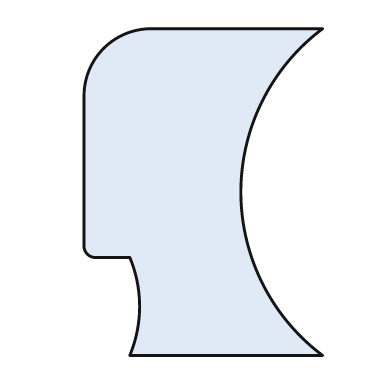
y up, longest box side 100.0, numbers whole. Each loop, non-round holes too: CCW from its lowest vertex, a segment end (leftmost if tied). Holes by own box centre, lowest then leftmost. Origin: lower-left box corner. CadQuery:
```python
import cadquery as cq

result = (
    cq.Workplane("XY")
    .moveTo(14.0, 0.0)
    .lineTo(73.0, 0.0)
    .threePointArc((48.0, 50.0), (73.0, 100.0))
    .lineTo(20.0, 100.0)
    .threePointArc((6.0, 94.0), (0.0, 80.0))
    .lineTo(0.0, 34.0)
    .threePointArc((1.0, 31.0), (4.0, 30.0))
    .lineTo(14.0, 30.0)
    .threePointArc((17.0, 15.0), (14.0, 0.0))
    .close()
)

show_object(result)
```